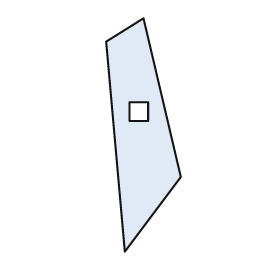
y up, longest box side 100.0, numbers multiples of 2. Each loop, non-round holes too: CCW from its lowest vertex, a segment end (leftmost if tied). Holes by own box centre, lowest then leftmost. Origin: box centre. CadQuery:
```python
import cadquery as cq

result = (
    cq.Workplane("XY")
    .moveTo(-8.0, -50.0)
    .lineTo(16.0, -18.0)
    .lineTo(0.0, 50.0)
    .lineTo(-16.0, 40.0)
    .close()
    .moveTo(-6.0, 6.0)
    .lineTo(2.0, 6.0)
    .lineTo(2.0, 14.0)
    .lineTo(-6.0, 14.0)
    .close()
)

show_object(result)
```